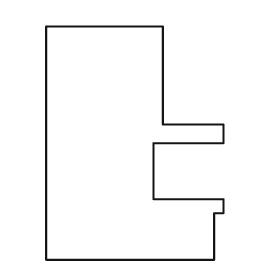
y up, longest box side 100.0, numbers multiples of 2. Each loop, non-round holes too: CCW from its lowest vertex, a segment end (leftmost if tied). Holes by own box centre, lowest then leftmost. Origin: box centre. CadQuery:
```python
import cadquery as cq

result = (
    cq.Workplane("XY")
    .moveTo(-38.0, -50.0)
    .lineTo(34.0, -50.0)
    .lineTo(34.0, -30.0)
    .lineTo(38.0, -30.0)
    .lineTo(38.0, -24.0)
    .lineTo(8.0, -24.0)
    .lineTo(8.0, 0.0)
    .lineTo(38.0, 0.0)
    .lineTo(38.0, 8.0)
    .lineTo(12.0, 8.0)
    .lineTo(12.0, 50.0)
    .lineTo(-38.0, 50.0)
    .close()
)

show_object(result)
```